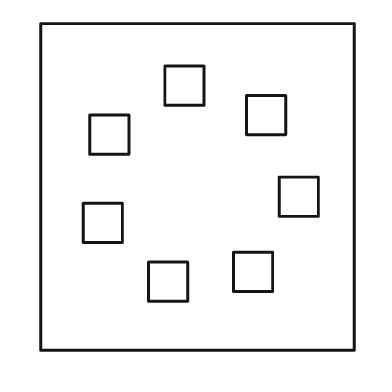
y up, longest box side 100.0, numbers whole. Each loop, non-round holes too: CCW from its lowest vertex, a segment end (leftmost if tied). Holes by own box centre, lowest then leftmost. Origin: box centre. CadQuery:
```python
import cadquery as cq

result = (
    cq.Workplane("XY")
    .moveTo(-48.0, -50.0)
    .lineTo(48.0, -50.0)
    .lineTo(48.0, 50.0)
    .lineTo(-48.0, 50.0)
    .close()
    .moveTo(-15.0, -35.0)
    .lineTo(-3.0, -35.0)
    .lineTo(-3.0, -23.0)
    .lineTo(-15.0, -23.0)
    .close()
    .moveTo(11.0, -32.0)
    .lineTo(23.0, -32.0)
    .lineTo(23.0, -20.0)
    .lineTo(11.0, -20.0)
    .close()
    .moveTo(-35.0, -17.0)
    .lineTo(-23.0, -17.0)
    .lineTo(-23.0, -5.0)
    .lineTo(-35.0, -5.0)
    .close()
    .moveTo(25.0, -9.0)
    .lineTo(37.0, -9.0)
    .lineTo(37.0, 3.0)
    .lineTo(25.0, 3.0)
    .close()
    .moveTo(-33.0, 10.0)
    .lineTo(-21.0, 10.0)
    .lineTo(-21.0, 22.0)
    .lineTo(-33.0, 22.0)
    .close()
    .moveTo(15.0, 16.0)
    .lineTo(27.0, 16.0)
    .lineTo(27.0, 28.0)
    .lineTo(15.0, 28.0)
    .close()
    .moveTo(-10.0, 25.0)
    .lineTo(2.0, 25.0)
    .lineTo(2.0, 37.0)
    .lineTo(-10.0, 37.0)
    .close()
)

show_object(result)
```